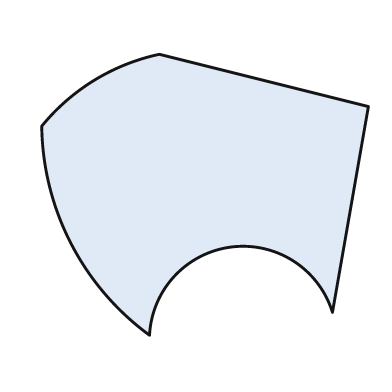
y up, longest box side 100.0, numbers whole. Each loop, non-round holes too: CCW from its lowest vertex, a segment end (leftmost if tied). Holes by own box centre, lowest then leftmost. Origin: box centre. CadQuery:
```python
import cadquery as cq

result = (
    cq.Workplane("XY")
    .moveTo(-17.0, -43.0)
    .threePointArc((8.0, -16.0), (39.0, -36.0))
    .lineTo(50.0, 27.0)
    .lineTo(-14.0, 43.0)
    .threePointArc((-34.0, 35.0), (-50.0, 21.0))
    .threePointArc((-41.0, -15.0), (-17.0, -43.0))
    .close()
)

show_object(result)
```